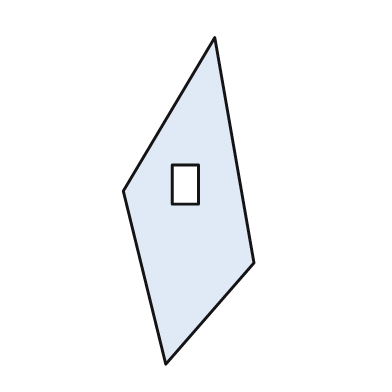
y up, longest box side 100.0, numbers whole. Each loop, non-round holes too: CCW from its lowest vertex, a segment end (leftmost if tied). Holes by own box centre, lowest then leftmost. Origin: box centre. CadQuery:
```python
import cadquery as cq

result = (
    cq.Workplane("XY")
    .moveTo(-7.0, -50.0)
    .lineTo(20.0, -19.0)
    .lineTo(8.0, 50.0)
    .lineTo(-20.0, 3.0)
    .close()
    .moveTo(-5.0, -1.0)
    .lineTo(3.0, -1.0)
    .lineTo(3.0, 11.0)
    .lineTo(-5.0, 11.0)
    .close()
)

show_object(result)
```